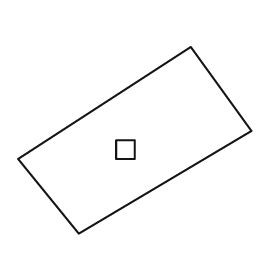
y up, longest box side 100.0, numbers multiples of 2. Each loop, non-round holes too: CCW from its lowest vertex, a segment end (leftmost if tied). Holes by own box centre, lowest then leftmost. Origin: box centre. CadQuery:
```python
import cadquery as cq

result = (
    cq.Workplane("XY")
    .moveTo(-24.0, -40.0)
    .lineTo(50.0, 4.0)
    .lineTo(24.0, 40.0)
    .lineTo(-50.0, -8.0)
    .close()
    .moveTo(-8.0, -8.0)
    .lineTo(0.0, -8.0)
    .lineTo(0.0, 0.0)
    .lineTo(-8.0, 0.0)
    .close()
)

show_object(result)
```